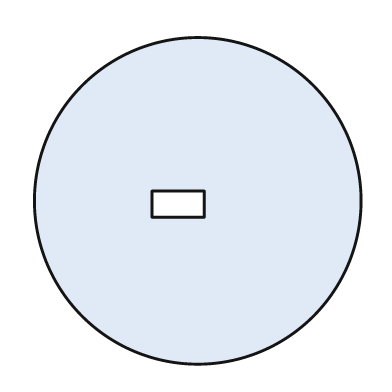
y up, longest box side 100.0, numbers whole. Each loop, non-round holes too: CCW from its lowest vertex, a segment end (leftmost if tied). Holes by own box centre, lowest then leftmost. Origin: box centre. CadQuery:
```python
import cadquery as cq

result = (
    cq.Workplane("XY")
    .moveTo(0.0, 0.0)
    .circle(50.0)
    .moveTo(-14.0, -5.0)
    .lineTo(2.0, -5.0)
    .lineTo(2.0, 3.0)
    .lineTo(-14.0, 3.0)
    .close()
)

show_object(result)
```